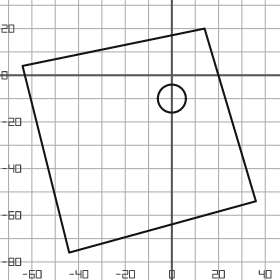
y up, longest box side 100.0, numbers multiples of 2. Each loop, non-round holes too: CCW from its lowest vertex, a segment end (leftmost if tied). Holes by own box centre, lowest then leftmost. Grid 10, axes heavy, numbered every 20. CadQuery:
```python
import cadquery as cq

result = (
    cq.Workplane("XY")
    .moveTo(-44.0, -76.0)
    .lineTo(36.0, -54.0)
    .lineTo(14.0, 20.0)
    .lineTo(-64.0, 4.0)
    .close()
    .moveTo(0.0, -10.0)
    .circle(6.0)
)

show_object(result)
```